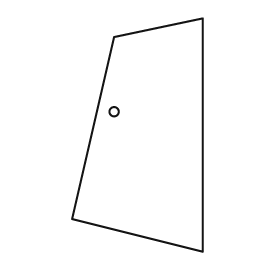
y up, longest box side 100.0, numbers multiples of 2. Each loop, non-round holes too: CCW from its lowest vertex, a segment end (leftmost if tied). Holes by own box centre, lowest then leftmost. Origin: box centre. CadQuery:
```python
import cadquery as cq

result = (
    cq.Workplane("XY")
    .moveTo(28.0, -50.0)
    .lineTo(28.0, 50.0)
    .lineTo(-10.0, 42.0)
    .lineTo(-28.0, -36.0)
    .close()
    .moveTo(-10.0, 10.0)
    .circle(2.0)
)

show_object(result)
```